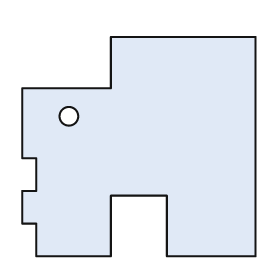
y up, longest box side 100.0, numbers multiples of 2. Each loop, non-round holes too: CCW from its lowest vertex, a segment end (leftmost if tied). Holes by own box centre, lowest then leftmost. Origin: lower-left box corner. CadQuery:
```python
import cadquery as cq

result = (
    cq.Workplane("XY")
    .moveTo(6.0, 0.0)
    .lineTo(38.0, 0.0)
    .lineTo(38.0, 26.0)
    .lineTo(62.0, 26.0)
    .lineTo(62.0, 0.0)
    .lineTo(100.0, 0.0)
    .lineTo(100.0, 94.0)
    .lineTo(38.0, 94.0)
    .lineTo(38.0, 72.0)
    .lineTo(0.0, 72.0)
    .lineTo(0.0, 42.0)
    .lineTo(6.0, 42.0)
    .lineTo(6.0, 28.0)
    .lineTo(0.0, 28.0)
    .lineTo(0.0, 14.0)
    .lineTo(6.0, 14.0)
    .close()
    .moveTo(20.0, 60.0)
    .circle(4.0)
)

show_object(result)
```